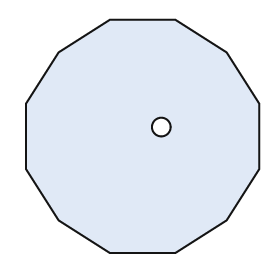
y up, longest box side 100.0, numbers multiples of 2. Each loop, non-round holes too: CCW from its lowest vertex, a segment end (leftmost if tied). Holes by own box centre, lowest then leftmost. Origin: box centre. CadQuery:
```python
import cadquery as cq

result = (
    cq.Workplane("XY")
    .moveTo(-14.0, -50.0)
    .lineTo(14.0, -50.0)
    .lineTo(36.0, -36.0)
    .lineTo(50.0, -14.0)
    .lineTo(50.0, 14.0)
    .lineTo(36.0, 36.0)
    .lineTo(14.0, 50.0)
    .lineTo(-14.0, 50.0)
    .lineTo(-36.0, 36.0)
    .lineTo(-50.0, 14.0)
    .lineTo(-50.0, -14.0)
    .lineTo(-36.0, -36.0)
    .close()
    .moveTo(8.0, 4.0)
    .circle(4.0)
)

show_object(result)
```